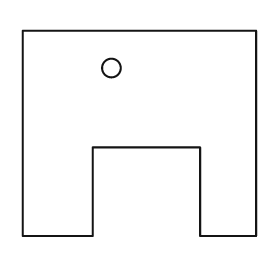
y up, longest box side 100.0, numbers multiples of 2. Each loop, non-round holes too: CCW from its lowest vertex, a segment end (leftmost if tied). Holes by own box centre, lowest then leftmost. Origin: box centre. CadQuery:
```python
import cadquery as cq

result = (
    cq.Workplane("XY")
    .moveTo(-50.0, -44.0)
    .lineTo(-20.0, -44.0)
    .lineTo(-20.0, -6.0)
    .lineTo(26.0, -6.0)
    .lineTo(26.0, -44.0)
    .lineTo(50.0, -44.0)
    .lineTo(50.0, 44.0)
    .lineTo(-50.0, 44.0)
    .close()
    .moveTo(-12.0, 28.0)
    .circle(4.0)
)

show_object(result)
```